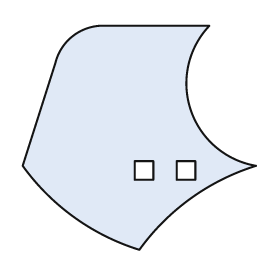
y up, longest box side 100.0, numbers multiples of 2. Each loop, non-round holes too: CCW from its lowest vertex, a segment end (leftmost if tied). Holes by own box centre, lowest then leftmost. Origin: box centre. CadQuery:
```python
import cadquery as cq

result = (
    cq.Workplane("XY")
    .moveTo(0.0, -48.0)
    .threePointArc((22.0, -26.0), (50.0, -12.0))
    .threePointArc((22.0, 12.0), (30.0, 48.0))
    .lineTo(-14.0, 48.0)
    .threePointArc((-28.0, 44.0), (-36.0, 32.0))
    .lineTo(-50.0, -12.0)
    .threePointArc((-28.0, -34.0), (0.0, -48.0))
    .close()
    .moveTo(-2.0, -18.0)
    .lineTo(6.0, -18.0)
    .lineTo(6.0, -10.0)
    .lineTo(-2.0, -10.0)
    .close()
    .moveTo(16.0, -18.0)
    .lineTo(24.0, -18.0)
    .lineTo(24.0, -10.0)
    .lineTo(16.0, -10.0)
    .close()
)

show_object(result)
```